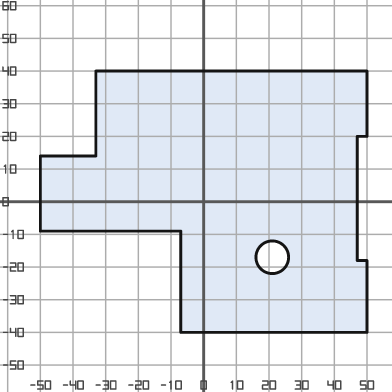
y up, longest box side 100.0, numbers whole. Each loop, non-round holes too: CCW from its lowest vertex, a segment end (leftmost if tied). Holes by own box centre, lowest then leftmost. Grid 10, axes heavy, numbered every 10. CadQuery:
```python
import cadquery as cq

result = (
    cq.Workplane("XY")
    .moveTo(-7.0, -40.0)
    .lineTo(50.0, -40.0)
    .lineTo(50.0, -18.0)
    .lineTo(47.0, -18.0)
    .lineTo(47.0, 20.0)
    .lineTo(50.0, 20.0)
    .lineTo(50.0, 40.0)
    .lineTo(-33.0, 40.0)
    .lineTo(-33.0, 14.0)
    .lineTo(-50.0, 14.0)
    .lineTo(-50.0, -9.0)
    .lineTo(-7.0, -9.0)
    .close()
    .moveTo(21.0, -17.0)
    .circle(5.0)
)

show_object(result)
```